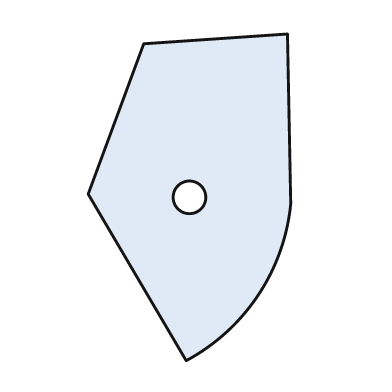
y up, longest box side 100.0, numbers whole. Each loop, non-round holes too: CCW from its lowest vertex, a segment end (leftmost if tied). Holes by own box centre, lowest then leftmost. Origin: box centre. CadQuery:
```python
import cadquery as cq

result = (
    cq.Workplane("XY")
    .moveTo(-1.0, -50.0)
    .threePointArc((21.0, -30.0), (31.0, -2.0))
    .lineTo(30.0, 50.0)
    .lineTo(-14.0, 47.0)
    .lineTo(-31.0, 1.0)
    .close()
    .moveTo(0.0, 0.0)
    .circle(5.0)
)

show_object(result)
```